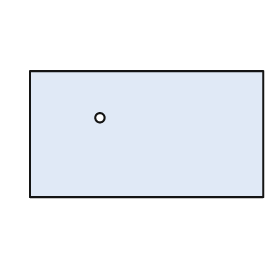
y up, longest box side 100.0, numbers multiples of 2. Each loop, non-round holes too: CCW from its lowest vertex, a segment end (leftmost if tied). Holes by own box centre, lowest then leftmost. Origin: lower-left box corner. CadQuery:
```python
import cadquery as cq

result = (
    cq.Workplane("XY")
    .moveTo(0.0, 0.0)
    .lineTo(100.0, 0.0)
    .lineTo(100.0, 54.0)
    .lineTo(0.0, 54.0)
    .close()
    .moveTo(30.0, 34.0)
    .circle(2.0)
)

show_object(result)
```